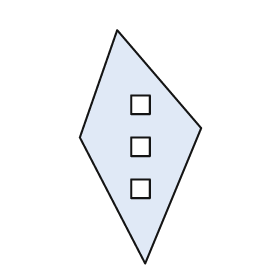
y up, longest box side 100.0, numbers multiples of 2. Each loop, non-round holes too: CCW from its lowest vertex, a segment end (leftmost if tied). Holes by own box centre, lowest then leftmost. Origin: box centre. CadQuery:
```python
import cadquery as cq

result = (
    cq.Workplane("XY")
    .moveTo(2.0, -50.0)
    .lineTo(26.0, 8.0)
    .lineTo(-10.0, 50.0)
    .lineTo(-26.0, 4.0)
    .close()
    .moveTo(-4.0, -22.0)
    .lineTo(4.0, -22.0)
    .lineTo(4.0, -14.0)
    .lineTo(-4.0, -14.0)
    .close()
    .moveTo(-4.0, -4.0)
    .lineTo(4.0, -4.0)
    .lineTo(4.0, 4.0)
    .lineTo(-4.0, 4.0)
    .close()
    .moveTo(-4.0, 14.0)
    .lineTo(4.0, 14.0)
    .lineTo(4.0, 22.0)
    .lineTo(-4.0, 22.0)
    .close()
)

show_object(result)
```